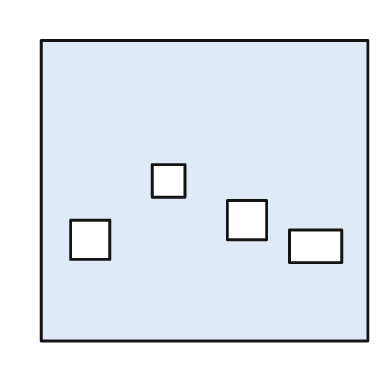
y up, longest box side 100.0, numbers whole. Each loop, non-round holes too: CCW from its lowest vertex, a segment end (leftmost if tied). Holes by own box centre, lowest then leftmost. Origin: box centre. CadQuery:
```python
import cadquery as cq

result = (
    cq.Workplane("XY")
    .moveTo(-50.0, -46.0)
    .lineTo(50.0, -46.0)
    .lineTo(50.0, 46.0)
    .lineTo(-50.0, 46.0)
    .close()
    .moveTo(26.0, -22.0)
    .lineTo(42.0, -22.0)
    .lineTo(42.0, -12.0)
    .lineTo(26.0, -12.0)
    .close()
    .moveTo(-41.0, -21.0)
    .lineTo(-29.0, -21.0)
    .lineTo(-29.0, -9.0)
    .lineTo(-41.0, -9.0)
    .close()
    .moveTo(7.0, -15.0)
    .lineTo(19.0, -15.0)
    .lineTo(19.0, -3.0)
    .lineTo(7.0, -3.0)
    .close()
    .moveTo(-16.0, -2.0)
    .lineTo(-6.0, -2.0)
    .lineTo(-6.0, 8.0)
    .lineTo(-16.0, 8.0)
    .close()
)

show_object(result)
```